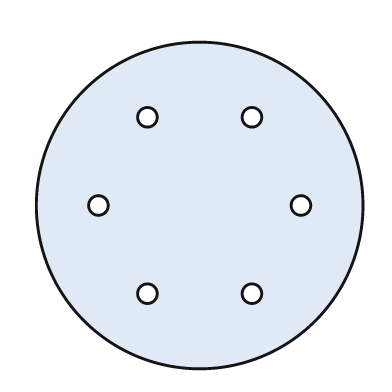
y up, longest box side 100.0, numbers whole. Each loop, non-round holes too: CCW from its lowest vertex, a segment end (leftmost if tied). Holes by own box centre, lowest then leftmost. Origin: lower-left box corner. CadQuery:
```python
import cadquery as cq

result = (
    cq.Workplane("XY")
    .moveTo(50.0, 50.0)
    .circle(50.0)
    .moveTo(34.0, 23.0)
    .circle(3.0)
    .moveTo(66.0, 23.0)
    .circle(3.0)
    .moveTo(19.0, 50.0)
    .circle(3.0)
    .moveTo(81.0, 50.0)
    .circle(3.0)
    .moveTo(34.0, 77.0)
    .circle(3.0)
    .moveTo(66.0, 77.0)
    .circle(3.0)
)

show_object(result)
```